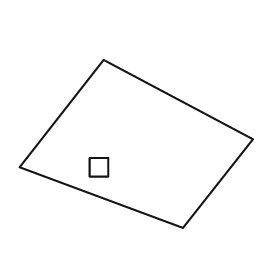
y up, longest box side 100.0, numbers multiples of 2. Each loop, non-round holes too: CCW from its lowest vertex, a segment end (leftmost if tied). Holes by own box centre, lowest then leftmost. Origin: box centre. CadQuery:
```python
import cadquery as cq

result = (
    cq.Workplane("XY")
    .moveTo(20.0, -36.0)
    .lineTo(50.0, 2.0)
    .lineTo(-14.0, 36.0)
    .lineTo(-50.0, -10.0)
    .close()
    .moveTo(-20.0, -14.0)
    .lineTo(-12.0, -14.0)
    .lineTo(-12.0, -6.0)
    .lineTo(-20.0, -6.0)
    .close()
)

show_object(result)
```